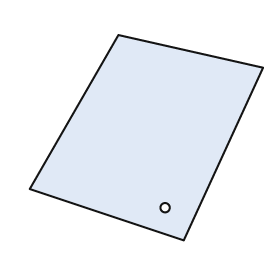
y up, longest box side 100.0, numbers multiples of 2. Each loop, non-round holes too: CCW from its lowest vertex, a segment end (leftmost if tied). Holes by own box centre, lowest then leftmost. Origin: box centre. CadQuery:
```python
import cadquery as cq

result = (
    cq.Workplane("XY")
    .moveTo(16.0, -44.0)
    .lineTo(50.0, 30.0)
    .lineTo(-12.0, 44.0)
    .lineTo(-50.0, -22.0)
    .close()
    .moveTo(8.0, -30.0)
    .circle(2.0)
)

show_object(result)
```